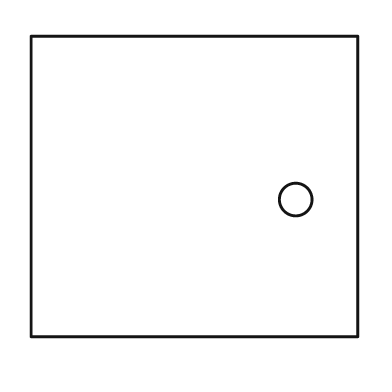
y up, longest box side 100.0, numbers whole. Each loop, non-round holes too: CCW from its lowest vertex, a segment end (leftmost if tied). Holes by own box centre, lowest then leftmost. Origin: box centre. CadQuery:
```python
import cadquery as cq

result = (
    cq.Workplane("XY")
    .moveTo(-50.0, -46.0)
    .lineTo(50.0, -46.0)
    .lineTo(50.0, 46.0)
    .lineTo(-50.0, 46.0)
    .close()
    .moveTo(31.0, -4.0)
    .circle(5.0)
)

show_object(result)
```